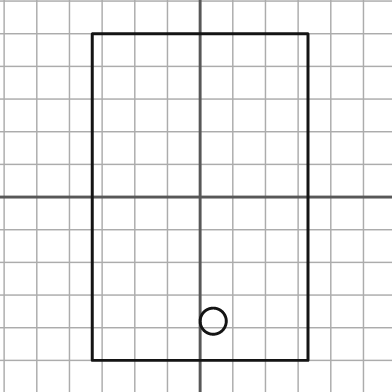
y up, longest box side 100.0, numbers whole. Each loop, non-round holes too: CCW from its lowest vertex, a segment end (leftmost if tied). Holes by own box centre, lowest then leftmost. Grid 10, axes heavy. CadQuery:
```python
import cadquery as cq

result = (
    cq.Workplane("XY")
    .moveTo(-33.0, -50.0)
    .lineTo(33.0, -50.0)
    .lineTo(33.0, 50.0)
    .lineTo(-33.0, 50.0)
    .close()
    .moveTo(4.0, -38.0)
    .circle(4.0)
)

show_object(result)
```